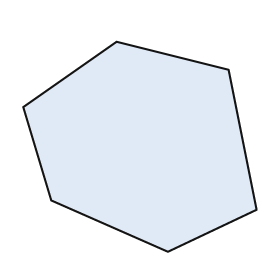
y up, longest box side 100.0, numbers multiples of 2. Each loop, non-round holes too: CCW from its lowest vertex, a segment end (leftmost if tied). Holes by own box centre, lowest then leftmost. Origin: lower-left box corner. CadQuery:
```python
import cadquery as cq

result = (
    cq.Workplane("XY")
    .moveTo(62.0, 0.0)
    .lineTo(100.0, 18.0)
    .lineTo(88.0, 78.0)
    .lineTo(40.0, 90.0)
    .lineTo(0.0, 62.0)
    .lineTo(12.0, 22.0)
    .close()
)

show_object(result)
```